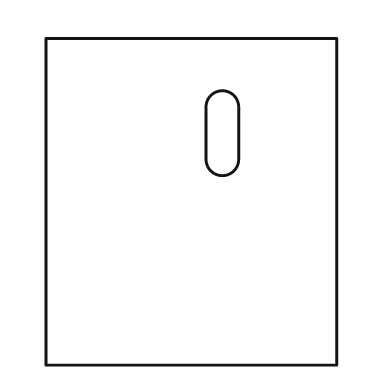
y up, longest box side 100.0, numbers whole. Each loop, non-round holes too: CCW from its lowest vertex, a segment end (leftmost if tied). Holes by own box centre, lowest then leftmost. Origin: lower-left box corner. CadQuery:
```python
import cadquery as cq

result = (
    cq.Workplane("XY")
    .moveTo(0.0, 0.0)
    .lineTo(89.0, 0.0)
    .lineTo(89.0, 100.0)
    .lineTo(0.0, 100.0)
    .close()
    .moveTo(49.0, 63.0)
    .threePointArc((54.0, 58.0), (59.0, 63.0))
    .lineTo(59.0, 79.0)
    .threePointArc((54.0, 84.0), (49.0, 79.0))
    .close()
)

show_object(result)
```